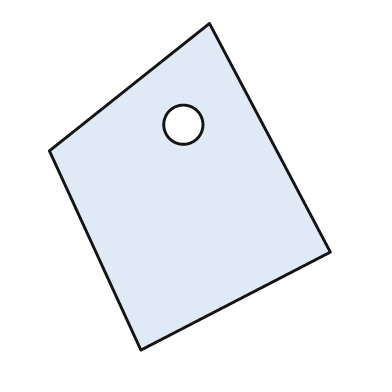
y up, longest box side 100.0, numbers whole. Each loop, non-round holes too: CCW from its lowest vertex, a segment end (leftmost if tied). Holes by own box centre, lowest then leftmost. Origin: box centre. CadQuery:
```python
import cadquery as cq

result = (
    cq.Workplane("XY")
    .moveTo(-15.0, -50.0)
    .lineTo(43.0, -20.0)
    .lineTo(6.0, 50.0)
    .lineTo(-43.0, 11.0)
    .close()
    .moveTo(-2.0, 19.0)
    .circle(6.0)
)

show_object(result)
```